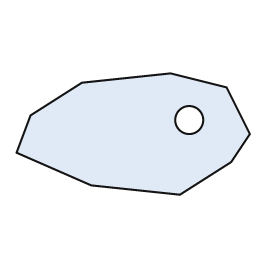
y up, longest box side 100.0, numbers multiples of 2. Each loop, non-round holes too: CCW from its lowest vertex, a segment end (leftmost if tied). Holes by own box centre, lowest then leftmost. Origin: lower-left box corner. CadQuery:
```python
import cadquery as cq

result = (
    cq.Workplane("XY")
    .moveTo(70.0, 0.0)
    .lineTo(92.0, 14.0)
    .lineTo(100.0, 26.0)
    .lineTo(90.0, 46.0)
    .lineTo(66.0, 52.0)
    .lineTo(28.0, 48.0)
    .lineTo(6.0, 34.0)
    .lineTo(0.0, 18.0)
    .lineTo(32.0, 4.0)
    .close()
    .moveTo(74.0, 32.0)
    .circle(6.0)
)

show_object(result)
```